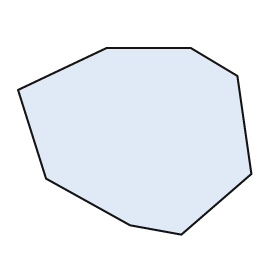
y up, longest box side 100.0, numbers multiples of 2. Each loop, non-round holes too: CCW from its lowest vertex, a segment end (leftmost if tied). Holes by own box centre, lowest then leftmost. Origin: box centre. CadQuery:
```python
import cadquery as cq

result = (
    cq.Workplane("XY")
    .moveTo(20.0, -40.0)
    .lineTo(50.0, -14.0)
    .lineTo(44.0, 28.0)
    .lineTo(24.0, 40.0)
    .lineTo(-12.0, 40.0)
    .lineTo(-50.0, 22.0)
    .lineTo(-38.0, -16.0)
    .lineTo(-2.0, -36.0)
    .close()
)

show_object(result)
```